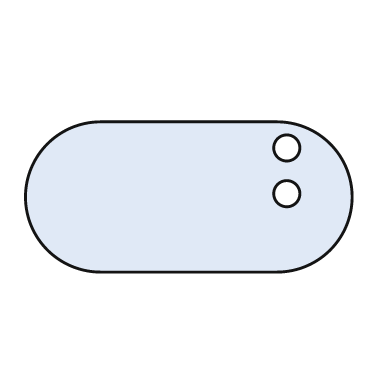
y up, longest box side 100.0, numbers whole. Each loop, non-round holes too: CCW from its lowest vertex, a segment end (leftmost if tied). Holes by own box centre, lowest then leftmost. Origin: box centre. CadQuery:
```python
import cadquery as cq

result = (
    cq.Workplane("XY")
    .moveTo(-27.0, -23.0)
    .lineTo(27.0, -23.0)
    .threePointArc((50.0, 0.0), (27.0, 23.0))
    .lineTo(-27.0, 23.0)
    .threePointArc((-50.0, 0.0), (-27.0, -23.0))
    .close()
    .moveTo(30.0, 1.0)
    .circle(4.0)
    .moveTo(30.0, 15.0)
    .circle(4.0)
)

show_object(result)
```